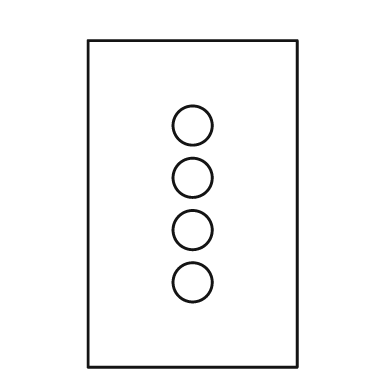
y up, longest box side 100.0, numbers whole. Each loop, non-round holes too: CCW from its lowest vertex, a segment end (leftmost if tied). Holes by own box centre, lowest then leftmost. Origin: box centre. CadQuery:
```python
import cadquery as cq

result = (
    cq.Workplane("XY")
    .moveTo(-32.0, -50.0)
    .lineTo(32.0, -50.0)
    .lineTo(32.0, 50.0)
    .lineTo(-32.0, 50.0)
    .close()
    .moveTo(0.0, -24.0)
    .circle(6.0)
    .moveTo(0.0, -8.0)
    .circle(6.0)
    .moveTo(0.0, 8.0)
    .circle(6.0)
    .moveTo(0.0, 24.0)
    .circle(6.0)
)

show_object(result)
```